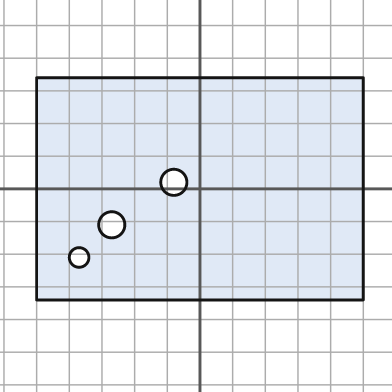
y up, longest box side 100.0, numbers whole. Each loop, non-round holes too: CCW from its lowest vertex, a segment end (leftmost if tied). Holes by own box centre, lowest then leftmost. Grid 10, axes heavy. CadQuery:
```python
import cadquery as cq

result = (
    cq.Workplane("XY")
    .moveTo(-50.0, -34.0)
    .lineTo(50.0, -34.0)
    .lineTo(50.0, 34.0)
    .lineTo(-50.0, 34.0)
    .close()
    .moveTo(-37.0, -21.0)
    .circle(3.0)
    .moveTo(-27.0, -11.0)
    .circle(4.0)
    .moveTo(-8.0, 2.0)
    .circle(4.0)
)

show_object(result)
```